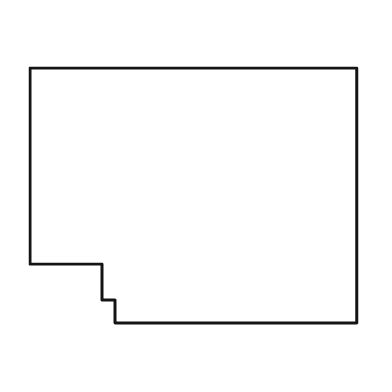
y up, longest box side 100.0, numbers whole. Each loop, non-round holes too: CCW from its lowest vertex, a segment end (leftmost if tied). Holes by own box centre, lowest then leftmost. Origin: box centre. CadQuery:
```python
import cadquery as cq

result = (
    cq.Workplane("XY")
    .moveTo(-24.0, -39.0)
    .lineTo(50.0, -39.0)
    .lineTo(50.0, 39.0)
    .lineTo(-50.0, 39.0)
    .lineTo(-50.0, -21.0)
    .lineTo(-28.0, -21.0)
    .lineTo(-28.0, -32.0)
    .lineTo(-24.0, -32.0)
    .close()
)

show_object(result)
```